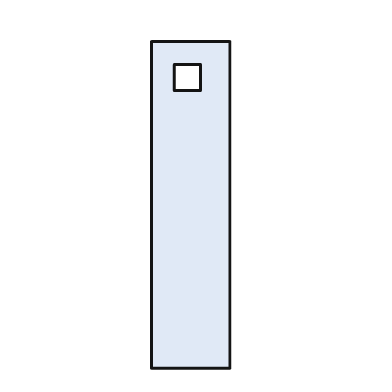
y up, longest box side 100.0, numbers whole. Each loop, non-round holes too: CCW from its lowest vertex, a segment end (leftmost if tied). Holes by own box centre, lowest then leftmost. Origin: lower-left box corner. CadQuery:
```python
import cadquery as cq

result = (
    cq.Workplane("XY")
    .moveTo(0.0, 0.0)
    .lineTo(24.0, 0.0)
    .lineTo(24.0, 100.0)
    .lineTo(0.0, 100.0)
    .close()
    .moveTo(7.0, 85.0)
    .lineTo(15.0, 85.0)
    .lineTo(15.0, 93.0)
    .lineTo(7.0, 93.0)
    .close()
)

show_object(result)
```